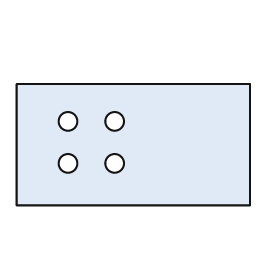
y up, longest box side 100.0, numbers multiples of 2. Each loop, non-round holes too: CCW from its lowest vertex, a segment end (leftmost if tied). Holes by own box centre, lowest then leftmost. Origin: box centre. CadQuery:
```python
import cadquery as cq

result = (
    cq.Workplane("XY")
    .moveTo(-50.0, -26.0)
    .lineTo(50.0, -26.0)
    .lineTo(50.0, 26.0)
    .lineTo(-50.0, 26.0)
    .close()
    .moveTo(-28.0, -8.0)
    .circle(4.0)
    .moveTo(-8.0, -8.0)
    .circle(4.0)
    .moveTo(-28.0, 10.0)
    .circle(4.0)
    .moveTo(-8.0, 10.0)
    .circle(4.0)
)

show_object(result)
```